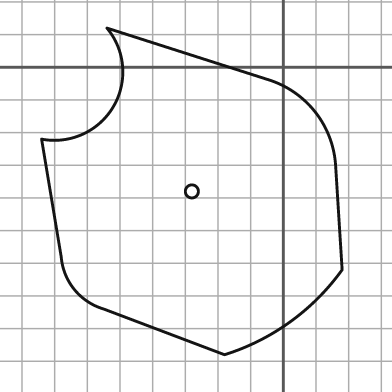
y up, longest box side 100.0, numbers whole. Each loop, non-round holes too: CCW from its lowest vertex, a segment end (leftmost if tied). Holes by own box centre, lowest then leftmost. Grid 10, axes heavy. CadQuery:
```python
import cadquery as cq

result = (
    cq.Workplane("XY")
    .moveTo(-18.0, -88.0)
    .threePointArc((2.0, -78.0), (18.0, -62.0))
    .lineTo(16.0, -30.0)
    .threePointArc((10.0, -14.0), (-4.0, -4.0))
    .lineTo(-54.0, 12.0)
    .threePointArc((-52.0, -12.0), (-74.0, -22.0))
    .lineTo(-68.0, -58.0)
    .threePointArc((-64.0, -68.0), (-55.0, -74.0))
    .close()
    .moveTo(-28.0, -38.0)
    .circle(2.0)
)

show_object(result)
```